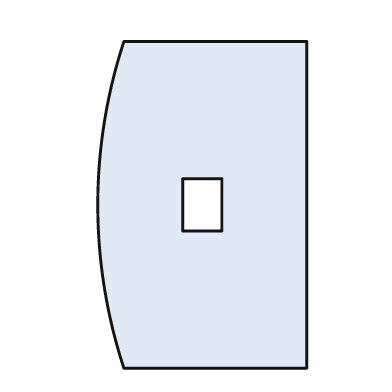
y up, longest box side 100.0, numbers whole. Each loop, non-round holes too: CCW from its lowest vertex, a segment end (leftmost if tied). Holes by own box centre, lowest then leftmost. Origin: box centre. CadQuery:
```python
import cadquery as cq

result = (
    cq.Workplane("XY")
    .moveTo(-24.0, -50.0)
    .lineTo(32.0, -50.0)
    .lineTo(32.0, 50.0)
    .lineTo(-24.0, 50.0)
    .threePointArc((-32.0, 0.0), (-24.0, -50.0))
    .close()
    .moveTo(-6.0, -8.0)
    .lineTo(6.0, -8.0)
    .lineTo(6.0, 8.0)
    .lineTo(-6.0, 8.0)
    .close()
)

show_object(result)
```